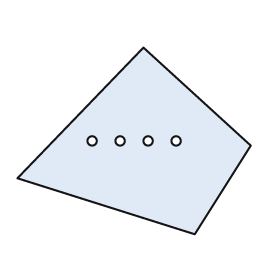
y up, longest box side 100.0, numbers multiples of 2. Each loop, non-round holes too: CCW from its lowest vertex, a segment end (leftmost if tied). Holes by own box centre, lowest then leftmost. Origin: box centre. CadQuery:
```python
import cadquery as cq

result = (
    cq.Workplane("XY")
    .moveTo(26.0, -40.0)
    .lineTo(50.0, -2.0)
    .lineTo(4.0, 40.0)
    .lineTo(-50.0, -16.0)
    .close()
    .moveTo(-18.0, 0.0)
    .circle(2.0)
    .moveTo(-6.0, 0.0)
    .circle(2.0)
    .moveTo(6.0, 0.0)
    .circle(2.0)
    .moveTo(18.0, 0.0)
    .circle(2.0)
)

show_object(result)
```